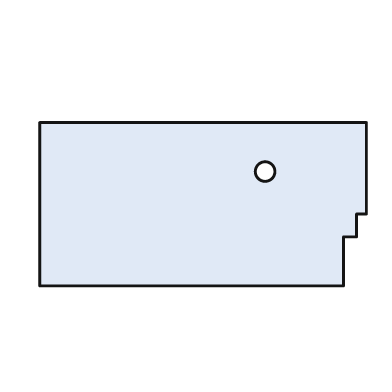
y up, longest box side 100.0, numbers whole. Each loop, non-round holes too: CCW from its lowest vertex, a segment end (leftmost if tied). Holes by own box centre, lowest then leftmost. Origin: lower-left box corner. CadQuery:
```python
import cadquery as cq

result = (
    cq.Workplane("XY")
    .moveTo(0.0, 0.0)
    .lineTo(93.0, 0.0)
    .lineTo(93.0, 15.0)
    .lineTo(97.0, 15.0)
    .lineTo(97.0, 22.0)
    .lineTo(100.0, 22.0)
    .lineTo(100.0, 50.0)
    .lineTo(0.0, 50.0)
    .close()
    .moveTo(69.0, 35.0)
    .circle(3.0)
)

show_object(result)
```